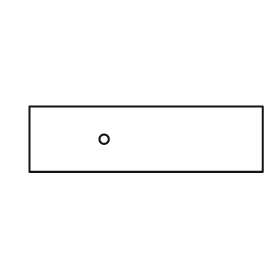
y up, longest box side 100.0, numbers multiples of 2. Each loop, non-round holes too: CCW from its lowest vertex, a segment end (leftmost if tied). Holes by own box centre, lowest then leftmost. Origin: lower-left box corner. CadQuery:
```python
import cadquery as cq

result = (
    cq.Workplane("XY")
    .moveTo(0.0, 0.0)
    .lineTo(100.0, 0.0)
    .lineTo(100.0, 28.0)
    .lineTo(0.0, 28.0)
    .close()
    .moveTo(32.0, 14.0)
    .circle(2.0)
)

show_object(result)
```